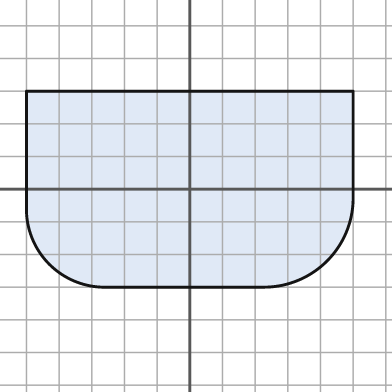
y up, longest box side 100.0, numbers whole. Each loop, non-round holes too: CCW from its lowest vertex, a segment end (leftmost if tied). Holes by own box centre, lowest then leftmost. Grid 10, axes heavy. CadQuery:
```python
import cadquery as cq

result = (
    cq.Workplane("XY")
    .moveTo(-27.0, -30.0)
    .lineTo(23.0, -30.0)
    .threePointArc((42.0, -22.0), (50.0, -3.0))
    .lineTo(50.0, 30.0)
    .lineTo(-50.0, 30.0)
    .lineTo(-50.0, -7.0)
    .threePointArc((-43.0, -23.0), (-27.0, -30.0))
    .close()
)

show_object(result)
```